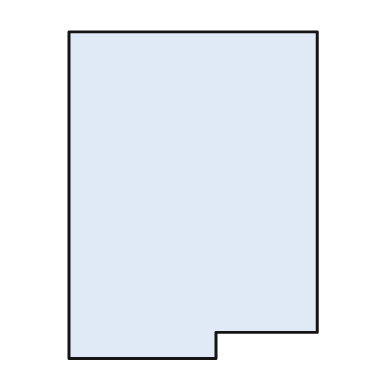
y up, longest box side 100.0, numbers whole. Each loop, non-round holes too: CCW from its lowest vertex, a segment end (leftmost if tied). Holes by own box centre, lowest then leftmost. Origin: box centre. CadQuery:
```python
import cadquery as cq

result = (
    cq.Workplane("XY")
    .moveTo(-38.0, -50.0)
    .lineTo(7.0, -50.0)
    .lineTo(7.0, -42.0)
    .lineTo(38.0, -42.0)
    .lineTo(38.0, 50.0)
    .lineTo(-38.0, 50.0)
    .close()
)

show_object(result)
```